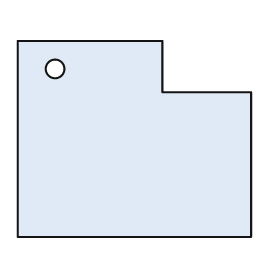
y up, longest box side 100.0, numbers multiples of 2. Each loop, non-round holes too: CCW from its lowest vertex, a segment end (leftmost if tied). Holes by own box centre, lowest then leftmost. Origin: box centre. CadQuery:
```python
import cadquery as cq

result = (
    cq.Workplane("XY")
    .moveTo(-50.0, -42.0)
    .lineTo(50.0, -42.0)
    .lineTo(50.0, 20.0)
    .lineTo(12.0, 20.0)
    .lineTo(12.0, 42.0)
    .lineTo(-50.0, 42.0)
    .close()
    .moveTo(-34.0, 30.0)
    .circle(4.0)
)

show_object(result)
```